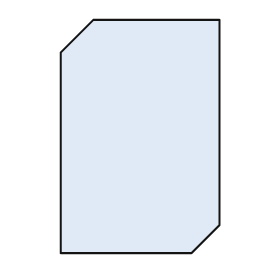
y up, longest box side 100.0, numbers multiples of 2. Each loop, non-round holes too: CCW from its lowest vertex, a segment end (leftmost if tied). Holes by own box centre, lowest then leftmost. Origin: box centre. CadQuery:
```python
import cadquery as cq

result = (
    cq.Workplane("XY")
    .moveTo(-34.0, -50.0)
    .lineTo(22.0, -50.0)
    .lineTo(34.0, -38.0)
    .lineTo(34.0, 50.0)
    .lineTo(-20.0, 50.0)
    .lineTo(-34.0, 36.0)
    .close()
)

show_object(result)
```